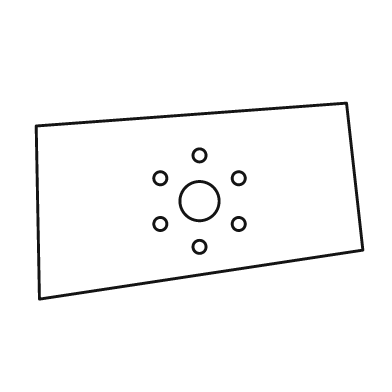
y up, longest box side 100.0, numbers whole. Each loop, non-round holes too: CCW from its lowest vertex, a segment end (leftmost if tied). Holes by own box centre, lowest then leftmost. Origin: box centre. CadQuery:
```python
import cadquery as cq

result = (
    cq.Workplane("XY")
    .moveTo(-49.0, -30.0)
    .lineTo(50.0, -15.0)
    .lineTo(45.0, 30.0)
    .lineTo(-50.0, 23.0)
    .close()
    .moveTo(0.0, -14.0)
    .circle(2.0)
    .moveTo(-12.0, -7.0)
    .circle(2.0)
    .moveTo(12.0, -7.0)
    .circle(2.0)
    .moveTo(0.0, 0.0)
    .circle(6.0)
    .moveTo(-12.0, 7.0)
    .circle(2.0)
    .moveTo(12.0, 7.0)
    .circle(2.0)
    .moveTo(0.0, 14.0)
    .circle(2.0)
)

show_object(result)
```